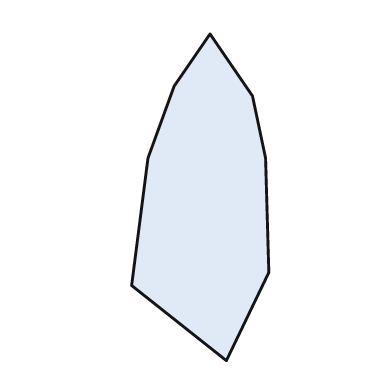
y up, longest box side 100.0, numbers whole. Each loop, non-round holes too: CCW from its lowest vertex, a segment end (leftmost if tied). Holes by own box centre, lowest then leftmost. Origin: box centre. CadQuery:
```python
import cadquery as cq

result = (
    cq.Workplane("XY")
    .moveTo(8.0, -50.0)
    .lineTo(21.0, -23.0)
    .lineTo(20.0, 12.0)
    .lineTo(16.0, 31.0)
    .lineTo(3.0, 50.0)
    .lineTo(-8.0, 34.0)
    .lineTo(-16.0, 12.0)
    .lineTo(-21.0, -27.0)
    .close()
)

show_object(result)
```